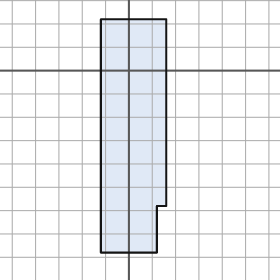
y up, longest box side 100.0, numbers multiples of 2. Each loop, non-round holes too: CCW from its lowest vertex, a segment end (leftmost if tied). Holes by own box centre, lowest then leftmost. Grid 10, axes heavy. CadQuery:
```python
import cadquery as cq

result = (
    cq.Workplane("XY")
    .moveTo(-12.0, -78.0)
    .lineTo(12.0, -78.0)
    .lineTo(12.0, -58.0)
    .lineTo(16.0, -58.0)
    .lineTo(16.0, 22.0)
    .lineTo(-12.0, 22.0)
    .close()
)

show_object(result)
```